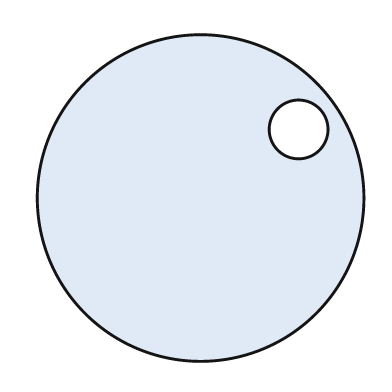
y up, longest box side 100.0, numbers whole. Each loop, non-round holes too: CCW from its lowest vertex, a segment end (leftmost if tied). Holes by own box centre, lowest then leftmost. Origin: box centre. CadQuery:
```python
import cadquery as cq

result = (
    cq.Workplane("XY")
    .moveTo(0.0, 0.0)
    .circle(50.0)
    .moveTo(30.0, 21.0)
    .circle(9.0)
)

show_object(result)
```